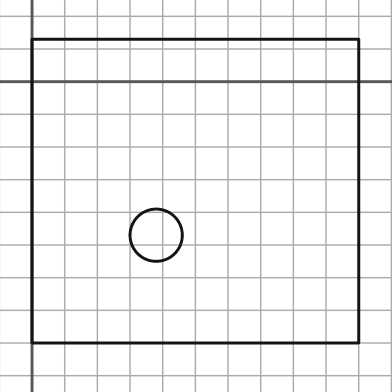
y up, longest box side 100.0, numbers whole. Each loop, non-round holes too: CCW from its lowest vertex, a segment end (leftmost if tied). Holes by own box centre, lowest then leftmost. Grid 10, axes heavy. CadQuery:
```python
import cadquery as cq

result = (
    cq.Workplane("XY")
    .moveTo(0.0, -80.0)
    .lineTo(100.0, -80.0)
    .lineTo(100.0, 13.0)
    .lineTo(0.0, 13.0)
    .close()
    .moveTo(38.0, -47.0)
    .circle(8.0)
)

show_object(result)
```